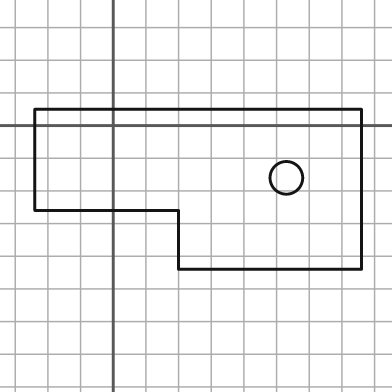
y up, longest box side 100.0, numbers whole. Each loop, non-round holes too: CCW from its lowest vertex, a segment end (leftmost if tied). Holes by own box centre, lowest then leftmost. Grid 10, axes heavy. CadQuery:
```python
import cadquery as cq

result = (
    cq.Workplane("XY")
    .moveTo(20.0, -44.0)
    .lineTo(76.0, -44.0)
    .lineTo(76.0, 5.0)
    .lineTo(-24.0, 5.0)
    .lineTo(-24.0, -26.0)
    .lineTo(20.0, -26.0)
    .close()
    .moveTo(53.0, -16.0)
    .circle(5.0)
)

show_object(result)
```